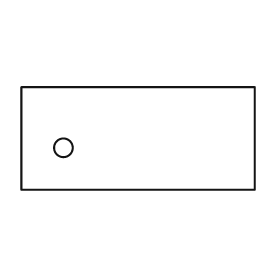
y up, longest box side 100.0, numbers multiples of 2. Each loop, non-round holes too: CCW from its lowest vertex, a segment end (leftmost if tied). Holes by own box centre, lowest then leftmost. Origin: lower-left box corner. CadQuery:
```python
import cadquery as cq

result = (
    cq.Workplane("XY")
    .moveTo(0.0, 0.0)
    .lineTo(100.0, 0.0)
    .lineTo(100.0, 44.0)
    .lineTo(0.0, 44.0)
    .close()
    .moveTo(18.0, 18.0)
    .circle(4.0)
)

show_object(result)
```